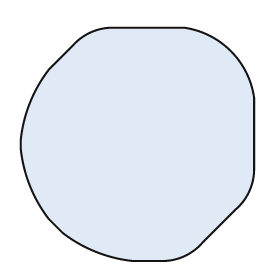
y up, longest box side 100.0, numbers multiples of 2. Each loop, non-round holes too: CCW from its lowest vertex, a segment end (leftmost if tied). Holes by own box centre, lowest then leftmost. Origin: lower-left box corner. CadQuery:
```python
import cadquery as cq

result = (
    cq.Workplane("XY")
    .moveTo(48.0, 0.0)
    .lineTo(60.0, 0.0)
    .threePointArc((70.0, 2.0), (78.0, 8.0))
    .lineTo(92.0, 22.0)
    .threePointArc((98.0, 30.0), (100.0, 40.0))
    .lineTo(100.0, 70.0)
    .threePointArc((90.0, 90.0), (70.0, 100.0))
    .lineTo(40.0, 100.0)
    .threePointArc((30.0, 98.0), (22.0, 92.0))
    .lineTo(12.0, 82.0)
    .threePointArc((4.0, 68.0), (0.0, 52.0))
    .lineTo(0.0, 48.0)
    .threePointArc((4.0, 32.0), (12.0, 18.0))
    .lineTo(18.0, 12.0)
    .threePointArc((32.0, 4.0), (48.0, 0.0))
    .close()
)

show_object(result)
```